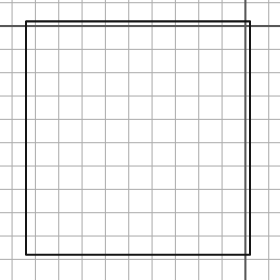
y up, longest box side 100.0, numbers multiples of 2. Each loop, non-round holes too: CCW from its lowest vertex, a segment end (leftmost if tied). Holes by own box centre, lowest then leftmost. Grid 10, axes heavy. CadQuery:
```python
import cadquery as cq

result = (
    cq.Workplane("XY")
    .moveTo(-94.0, -98.0)
    .lineTo(2.0, -98.0)
    .lineTo(2.0, 2.0)
    .lineTo(-94.0, 2.0)
    .close()
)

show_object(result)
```